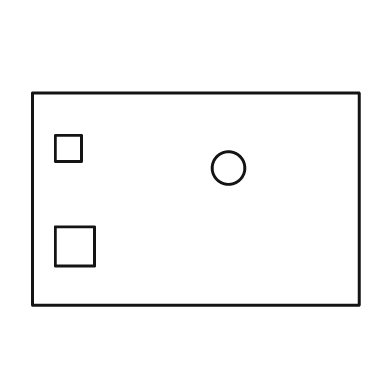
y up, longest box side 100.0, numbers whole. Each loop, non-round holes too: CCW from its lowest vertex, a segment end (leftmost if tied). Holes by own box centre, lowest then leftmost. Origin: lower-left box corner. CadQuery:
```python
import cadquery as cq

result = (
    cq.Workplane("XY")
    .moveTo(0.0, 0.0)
    .lineTo(100.0, 0.0)
    .lineTo(100.0, 65.0)
    .lineTo(0.0, 65.0)
    .close()
    .moveTo(7.0, 12.0)
    .lineTo(19.0, 12.0)
    .lineTo(19.0, 24.0)
    .lineTo(7.0, 24.0)
    .close()
    .moveTo(60.0, 42.0)
    .circle(5.0)
    .moveTo(7.0, 44.0)
    .lineTo(15.0, 44.0)
    .lineTo(15.0, 52.0)
    .lineTo(7.0, 52.0)
    .close()
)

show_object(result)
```